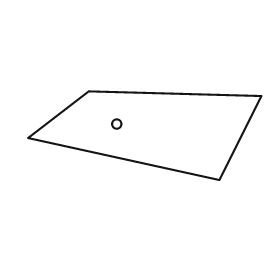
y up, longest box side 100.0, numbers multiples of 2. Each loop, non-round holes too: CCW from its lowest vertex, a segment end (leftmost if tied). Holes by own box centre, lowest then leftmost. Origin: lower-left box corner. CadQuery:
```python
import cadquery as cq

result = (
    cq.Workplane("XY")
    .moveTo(82.0, 0.0)
    .lineTo(100.0, 36.0)
    .lineTo(26.0, 38.0)
    .lineTo(0.0, 18.0)
    .close()
    .moveTo(38.0, 24.0)
    .circle(2.0)
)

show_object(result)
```